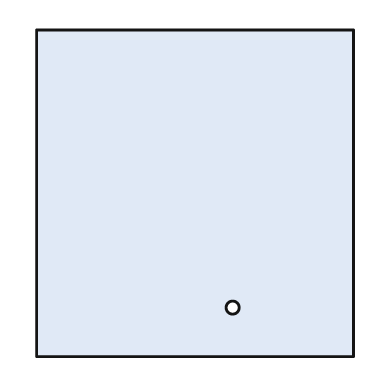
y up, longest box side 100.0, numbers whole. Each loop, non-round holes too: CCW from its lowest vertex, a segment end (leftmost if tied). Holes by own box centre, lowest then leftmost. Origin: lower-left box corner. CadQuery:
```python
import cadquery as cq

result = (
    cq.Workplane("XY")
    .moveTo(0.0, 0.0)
    .lineTo(97.0, 0.0)
    .lineTo(97.0, 100.0)
    .lineTo(0.0, 100.0)
    .close()
    .moveTo(60.0, 15.0)
    .circle(2.0)
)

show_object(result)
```